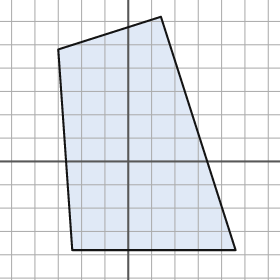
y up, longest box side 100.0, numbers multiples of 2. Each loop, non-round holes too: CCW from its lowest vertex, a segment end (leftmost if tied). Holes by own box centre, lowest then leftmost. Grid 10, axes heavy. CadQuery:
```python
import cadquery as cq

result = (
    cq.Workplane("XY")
    .moveTo(-24.0, -38.0)
    .lineTo(46.0, -38.0)
    .lineTo(14.0, 62.0)
    .lineTo(-30.0, 48.0)
    .close()
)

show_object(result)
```